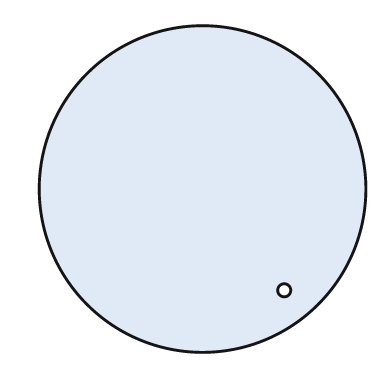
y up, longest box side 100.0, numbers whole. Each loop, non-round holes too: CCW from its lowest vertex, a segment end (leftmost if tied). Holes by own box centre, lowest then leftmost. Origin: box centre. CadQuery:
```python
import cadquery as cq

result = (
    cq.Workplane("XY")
    .moveTo(0.0, 0.0)
    .circle(50.0)
    .moveTo(25.0, -31.0)
    .circle(2.0)
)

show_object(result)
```